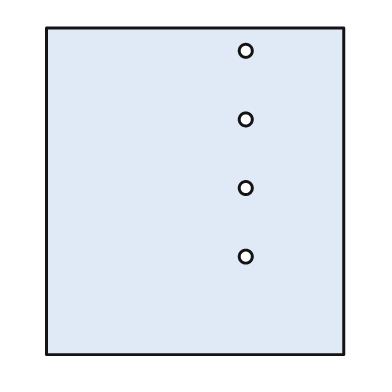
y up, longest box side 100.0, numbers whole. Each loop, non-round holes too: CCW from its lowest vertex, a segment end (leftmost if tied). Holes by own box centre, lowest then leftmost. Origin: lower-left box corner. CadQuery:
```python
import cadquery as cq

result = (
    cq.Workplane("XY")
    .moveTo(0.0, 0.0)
    .lineTo(91.0, 0.0)
    .lineTo(91.0, 100.0)
    .lineTo(0.0, 100.0)
    .close()
    .moveTo(61.0, 30.0)
    .circle(2.0)
    .moveTo(61.0, 51.0)
    .circle(2.0)
    .moveTo(61.0, 72.0)
    .circle(2.0)
    .moveTo(61.0, 93.0)
    .circle(2.0)
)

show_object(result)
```